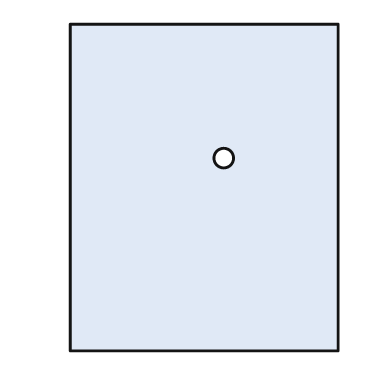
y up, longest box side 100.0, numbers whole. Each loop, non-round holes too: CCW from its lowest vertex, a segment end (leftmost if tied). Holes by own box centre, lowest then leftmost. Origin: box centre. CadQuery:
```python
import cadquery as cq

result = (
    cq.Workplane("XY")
    .moveTo(-41.0, -50.0)
    .lineTo(41.0, -50.0)
    .lineTo(41.0, 50.0)
    .lineTo(-41.0, 50.0)
    .close()
    .moveTo(6.0, 9.0)
    .circle(3.0)
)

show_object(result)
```